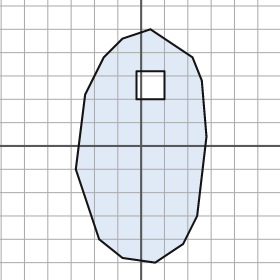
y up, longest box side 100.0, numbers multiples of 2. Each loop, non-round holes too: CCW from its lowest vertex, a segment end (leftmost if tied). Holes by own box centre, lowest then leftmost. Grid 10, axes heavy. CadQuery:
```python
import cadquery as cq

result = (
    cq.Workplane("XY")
    .moveTo(6.0, -50.0)
    .lineTo(18.0, -42.0)
    .lineTo(24.0, -30.0)
    .lineTo(28.0, 4.0)
    .lineTo(26.0, 28.0)
    .lineTo(22.0, 38.0)
    .lineTo(4.0, 50.0)
    .lineTo(-8.0, 46.0)
    .lineTo(-16.0, 38.0)
    .lineTo(-24.0, 22.0)
    .lineTo(-28.0, -10.0)
    .lineTo(-18.0, -40.0)
    .lineTo(-8.0, -48.0)
    .close()
    .moveTo(-2.0, 20.0)
    .lineTo(10.0, 20.0)
    .lineTo(10.0, 32.0)
    .lineTo(-2.0, 32.0)
    .close()
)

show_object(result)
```